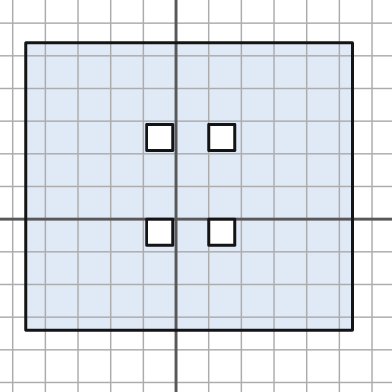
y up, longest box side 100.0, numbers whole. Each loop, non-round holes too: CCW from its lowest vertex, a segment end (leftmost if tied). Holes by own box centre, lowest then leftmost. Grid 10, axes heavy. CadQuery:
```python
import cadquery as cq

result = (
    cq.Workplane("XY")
    .moveTo(-46.0, -34.0)
    .lineTo(54.0, -34.0)
    .lineTo(54.0, 54.0)
    .lineTo(-46.0, 54.0)
    .close()
    .moveTo(-9.0, -8.0)
    .lineTo(-1.0, -8.0)
    .lineTo(-1.0, 0.0)
    .lineTo(-9.0, 0.0)
    .close()
    .moveTo(10.0, -8.0)
    .lineTo(18.0, -8.0)
    .lineTo(18.0, 0.0)
    .lineTo(10.0, 0.0)
    .close()
    .moveTo(-9.0, 21.0)
    .lineTo(-1.0, 21.0)
    .lineTo(-1.0, 29.0)
    .lineTo(-9.0, 29.0)
    .close()
    .moveTo(10.0, 21.0)
    .lineTo(18.0, 21.0)
    .lineTo(18.0, 29.0)
    .lineTo(10.0, 29.0)
    .close()
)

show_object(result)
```